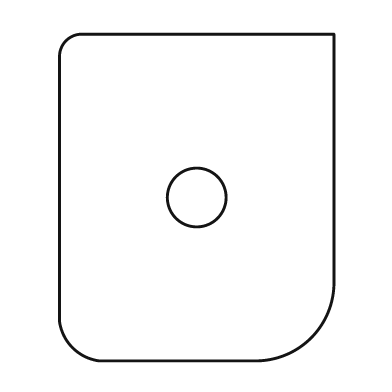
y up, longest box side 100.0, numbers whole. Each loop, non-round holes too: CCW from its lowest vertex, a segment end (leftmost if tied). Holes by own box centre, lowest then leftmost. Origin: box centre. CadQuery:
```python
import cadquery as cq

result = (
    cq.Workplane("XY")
    .moveTo(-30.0, -50.0)
    .lineTo(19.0, -50.0)
    .threePointArc((35.0, -43.0), (42.0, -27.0))
    .lineTo(42.0, 50.0)
    .lineTo(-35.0, 50.0)
    .threePointArc((-40.0, 48.0), (-42.0, 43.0))
    .lineTo(-42.0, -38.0)
    .threePointArc((-38.0, -46.0), (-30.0, -50.0))
    .close()
    .moveTo(0.0, 0.0)
    .circle(9.0)
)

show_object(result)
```